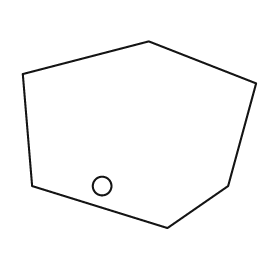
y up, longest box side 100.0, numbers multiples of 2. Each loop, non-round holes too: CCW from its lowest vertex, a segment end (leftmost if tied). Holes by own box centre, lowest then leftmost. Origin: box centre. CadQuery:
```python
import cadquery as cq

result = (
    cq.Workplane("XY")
    .moveTo(12.0, -40.0)
    .lineTo(38.0, -22.0)
    .lineTo(50.0, 22.0)
    .lineTo(4.0, 40.0)
    .lineTo(-50.0, 26.0)
    .lineTo(-46.0, -22.0)
    .close()
    .moveTo(-16.0, -22.0)
    .circle(4.0)
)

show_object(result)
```